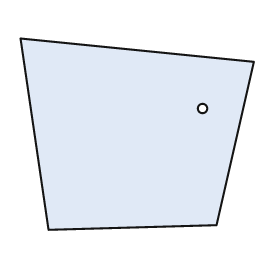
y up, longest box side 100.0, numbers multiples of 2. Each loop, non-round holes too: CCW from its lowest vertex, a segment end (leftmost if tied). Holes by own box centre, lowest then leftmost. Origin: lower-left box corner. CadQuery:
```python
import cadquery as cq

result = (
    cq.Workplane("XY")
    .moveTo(12.0, 0.0)
    .lineTo(84.0, 2.0)
    .lineTo(100.0, 72.0)
    .lineTo(0.0, 82.0)
    .close()
    .moveTo(78.0, 52.0)
    .circle(2.0)
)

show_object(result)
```